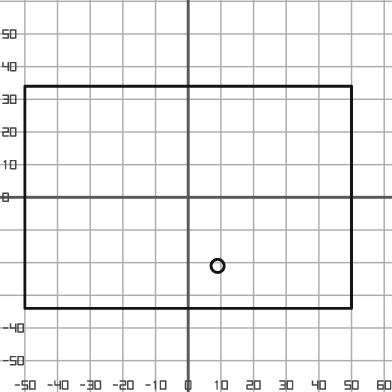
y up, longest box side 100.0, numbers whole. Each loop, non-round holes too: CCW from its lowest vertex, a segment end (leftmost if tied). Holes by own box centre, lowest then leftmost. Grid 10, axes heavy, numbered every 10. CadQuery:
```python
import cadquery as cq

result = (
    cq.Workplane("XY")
    .moveTo(-50.0, -34.0)
    .lineTo(50.0, -34.0)
    .lineTo(50.0, 34.0)
    .lineTo(-50.0, 34.0)
    .close()
    .moveTo(9.0, -21.0)
    .circle(2.0)
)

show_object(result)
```